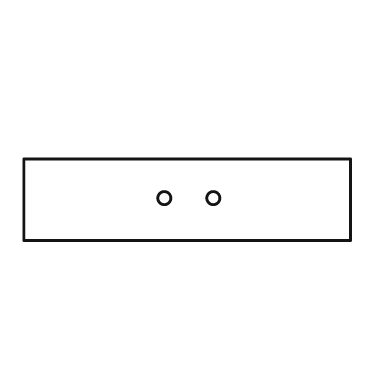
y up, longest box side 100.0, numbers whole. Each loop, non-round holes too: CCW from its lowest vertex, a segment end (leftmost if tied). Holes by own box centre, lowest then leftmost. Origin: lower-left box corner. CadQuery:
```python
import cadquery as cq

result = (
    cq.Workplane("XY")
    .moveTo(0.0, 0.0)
    .lineTo(100.0, 0.0)
    .lineTo(100.0, 25.0)
    .lineTo(0.0, 25.0)
    .close()
    .moveTo(43.0, 13.0)
    .circle(2.0)
    .moveTo(58.0, 13.0)
    .circle(2.0)
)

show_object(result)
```